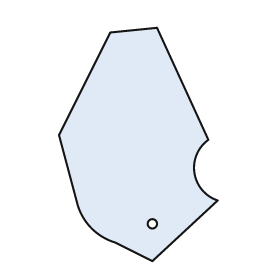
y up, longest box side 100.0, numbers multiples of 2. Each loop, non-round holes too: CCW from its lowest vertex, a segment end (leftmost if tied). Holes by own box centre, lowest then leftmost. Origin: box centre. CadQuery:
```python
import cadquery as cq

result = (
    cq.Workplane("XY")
    .moveTo(6.0, -50.0)
    .lineTo(34.0, -24.0)
    .threePointArc((24.0, -12.0), (30.0, 2.0))
    .lineTo(8.0, 50.0)
    .lineTo(-12.0, 48.0)
    .lineTo(-34.0, 4.0)
    .lineTo(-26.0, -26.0)
    .threePointArc((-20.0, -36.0), (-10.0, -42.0))
    .close()
    .moveTo(6.0, -34.0)
    .circle(2.0)
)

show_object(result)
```